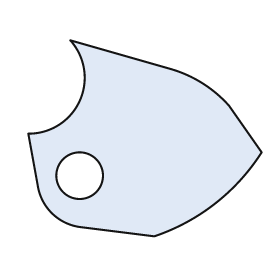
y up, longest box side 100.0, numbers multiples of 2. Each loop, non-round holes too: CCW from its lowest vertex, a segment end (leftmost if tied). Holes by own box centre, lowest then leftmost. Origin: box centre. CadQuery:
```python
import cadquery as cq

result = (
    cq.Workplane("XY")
    .moveTo(4.0, -42.0)
    .threePointArc((30.0, -28.0), (50.0, -6.0))
    .lineTo(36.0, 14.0)
    .threePointArc((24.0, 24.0), (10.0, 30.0))
    .lineTo(-32.0, 42.0)
    .threePointArc((-28.0, 16.0), (-50.0, 2.0))
    .lineTo(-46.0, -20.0)
    .threePointArc((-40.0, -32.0), (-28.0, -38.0))
    .close()
    .moveTo(-28.0, -16.0)
    .circle(10.0)
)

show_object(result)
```